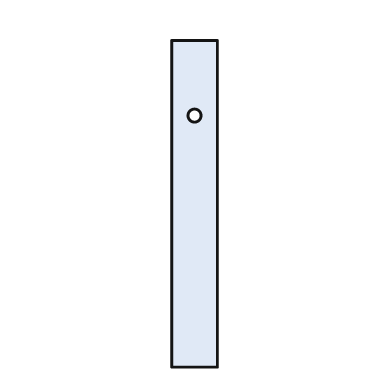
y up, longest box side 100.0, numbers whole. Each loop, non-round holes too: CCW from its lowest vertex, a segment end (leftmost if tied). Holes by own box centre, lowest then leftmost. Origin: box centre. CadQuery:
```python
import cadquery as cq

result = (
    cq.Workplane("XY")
    .moveTo(-7.0, -50.0)
    .lineTo(7.0, -50.0)
    .lineTo(7.0, 50.0)
    .lineTo(-7.0, 50.0)
    .close()
    .moveTo(0.0, 27.0)
    .circle(2.0)
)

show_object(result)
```